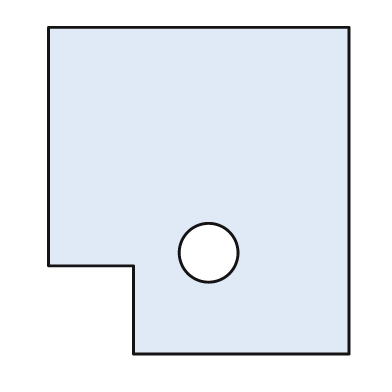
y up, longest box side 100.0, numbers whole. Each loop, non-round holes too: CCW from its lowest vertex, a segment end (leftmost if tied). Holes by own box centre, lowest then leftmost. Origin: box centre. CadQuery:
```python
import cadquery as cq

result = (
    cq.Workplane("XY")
    .moveTo(-20.0, -50.0)
    .lineTo(46.0, -50.0)
    .lineTo(46.0, 50.0)
    .lineTo(-46.0, 50.0)
    .lineTo(-46.0, -23.0)
    .lineTo(-20.0, -23.0)
    .close()
    .moveTo(3.0, -19.0)
    .circle(9.0)
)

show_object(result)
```